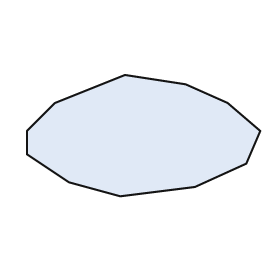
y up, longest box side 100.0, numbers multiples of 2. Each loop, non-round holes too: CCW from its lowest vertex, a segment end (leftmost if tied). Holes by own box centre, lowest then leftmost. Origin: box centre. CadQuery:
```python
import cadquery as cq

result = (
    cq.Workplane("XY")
    .moveTo(-10.0, -26.0)
    .lineTo(22.0, -22.0)
    .lineTo(44.0, -12.0)
    .lineTo(50.0, 2.0)
    .lineTo(36.0, 14.0)
    .lineTo(18.0, 22.0)
    .lineTo(-8.0, 26.0)
    .lineTo(-38.0, 14.0)
    .lineTo(-50.0, 2.0)
    .lineTo(-50.0, -8.0)
    .lineTo(-32.0, -20.0)
    .close()
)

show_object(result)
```